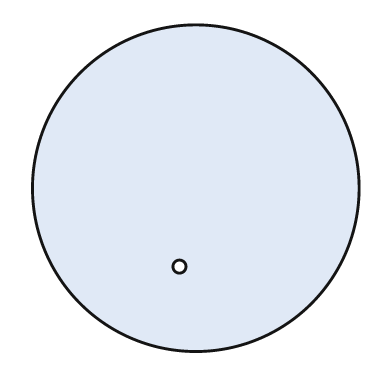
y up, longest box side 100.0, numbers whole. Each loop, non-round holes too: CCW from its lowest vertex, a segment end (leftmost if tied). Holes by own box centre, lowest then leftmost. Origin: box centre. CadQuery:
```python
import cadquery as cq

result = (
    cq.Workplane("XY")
    .moveTo(0.0, 0.0)
    .circle(50.0)
    .moveTo(-5.0, -24.0)
    .circle(2.0)
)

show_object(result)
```